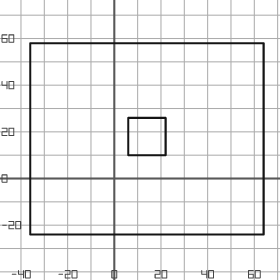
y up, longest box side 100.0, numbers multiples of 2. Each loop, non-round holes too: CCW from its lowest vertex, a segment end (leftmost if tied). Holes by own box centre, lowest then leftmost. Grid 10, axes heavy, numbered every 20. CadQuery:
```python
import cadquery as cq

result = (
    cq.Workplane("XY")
    .moveTo(-36.0, -24.0)
    .lineTo(64.0, -24.0)
    .lineTo(64.0, 58.0)
    .lineTo(-36.0, 58.0)
    .close()
    .moveTo(6.0, 10.0)
    .lineTo(22.0, 10.0)
    .lineTo(22.0, 26.0)
    .lineTo(6.0, 26.0)
    .close()
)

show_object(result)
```